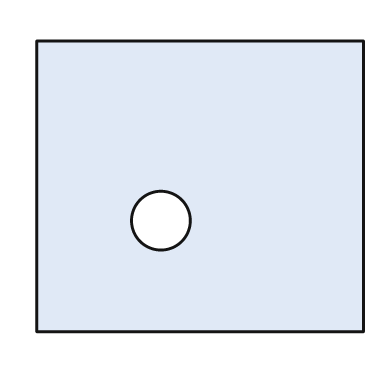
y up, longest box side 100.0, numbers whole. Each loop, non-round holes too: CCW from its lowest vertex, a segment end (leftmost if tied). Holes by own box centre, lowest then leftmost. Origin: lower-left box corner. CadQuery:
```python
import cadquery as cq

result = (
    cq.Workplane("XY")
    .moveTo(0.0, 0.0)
    .lineTo(100.0, 0.0)
    .lineTo(100.0, 89.0)
    .lineTo(0.0, 89.0)
    .close()
    .moveTo(38.0, 34.0)
    .circle(9.0)
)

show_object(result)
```